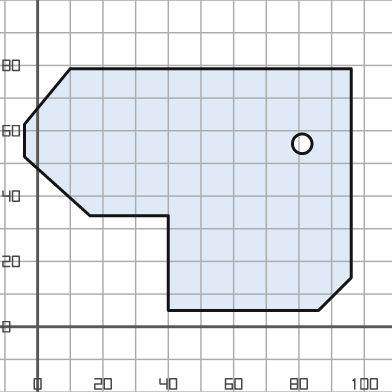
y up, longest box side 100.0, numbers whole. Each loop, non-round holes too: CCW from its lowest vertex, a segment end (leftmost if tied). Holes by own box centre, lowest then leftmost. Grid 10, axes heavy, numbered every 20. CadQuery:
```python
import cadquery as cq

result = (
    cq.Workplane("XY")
    .moveTo(40.0, 5.0)
    .lineTo(86.0, 5.0)
    .lineTo(96.0, 15.0)
    .lineTo(96.0, 79.0)
    .lineTo(10.0, 79.0)
    .lineTo(-4.0, 62.0)
    .lineTo(-4.0, 52.0)
    .lineTo(16.0, 34.0)
    .lineTo(40.0, 34.0)
    .close()
    .moveTo(81.0, 56.0)
    .circle(3.0)
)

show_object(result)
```